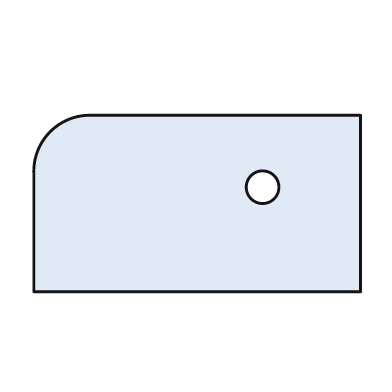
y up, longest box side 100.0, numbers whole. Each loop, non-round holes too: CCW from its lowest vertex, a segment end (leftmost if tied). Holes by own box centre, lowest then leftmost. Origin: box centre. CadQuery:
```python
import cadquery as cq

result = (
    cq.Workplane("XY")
    .moveTo(-50.0, -27.0)
    .lineTo(50.0, -27.0)
    .lineTo(50.0, 27.0)
    .lineTo(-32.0, 27.0)
    .threePointArc((-45.0, 22.0), (-50.0, 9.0))
    .close()
    .moveTo(20.0, 5.0)
    .circle(5.0)
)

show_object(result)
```